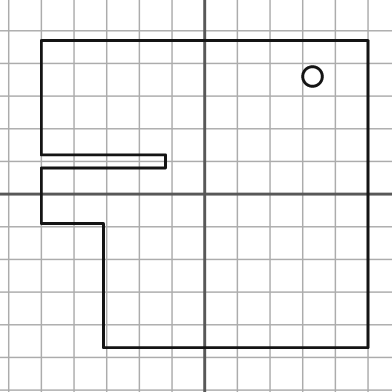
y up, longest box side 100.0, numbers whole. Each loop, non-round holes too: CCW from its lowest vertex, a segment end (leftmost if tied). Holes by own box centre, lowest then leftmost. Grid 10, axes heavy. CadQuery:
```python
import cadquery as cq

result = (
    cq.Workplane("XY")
    .moveTo(-31.0, -47.0)
    .lineTo(50.0, -47.0)
    .lineTo(50.0, 47.0)
    .lineTo(-50.0, 47.0)
    .lineTo(-50.0, 12.0)
    .lineTo(-12.0, 12.0)
    .lineTo(-12.0, 8.0)
    .lineTo(-50.0, 8.0)
    .lineTo(-50.0, -9.0)
    .lineTo(-31.0, -9.0)
    .close()
    .moveTo(33.0, 36.0)
    .circle(3.0)
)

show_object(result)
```